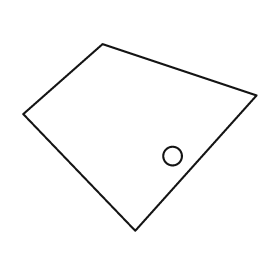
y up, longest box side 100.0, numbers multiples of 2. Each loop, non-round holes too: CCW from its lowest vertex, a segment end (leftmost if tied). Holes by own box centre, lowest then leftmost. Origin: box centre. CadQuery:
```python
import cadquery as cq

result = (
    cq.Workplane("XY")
    .moveTo(-2.0, -40.0)
    .lineTo(50.0, 18.0)
    .lineTo(-16.0, 40.0)
    .lineTo(-50.0, 10.0)
    .close()
    .moveTo(14.0, -8.0)
    .circle(4.0)
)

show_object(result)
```